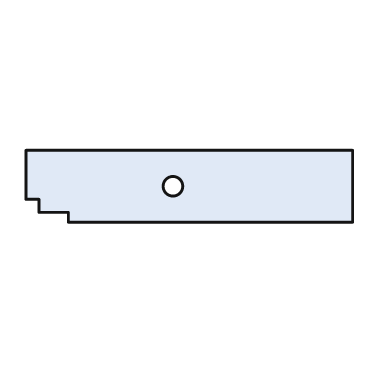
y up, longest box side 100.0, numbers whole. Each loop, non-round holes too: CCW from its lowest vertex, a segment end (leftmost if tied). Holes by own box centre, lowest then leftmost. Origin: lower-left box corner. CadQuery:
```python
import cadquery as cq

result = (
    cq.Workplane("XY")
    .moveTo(13.0, 0.0)
    .lineTo(100.0, 0.0)
    .lineTo(100.0, 22.0)
    .lineTo(0.0, 22.0)
    .lineTo(0.0, 7.0)
    .lineTo(4.0, 7.0)
    .lineTo(4.0, 3.0)
    .lineTo(13.0, 3.0)
    .close()
    .moveTo(45.0, 11.0)
    .circle(3.0)
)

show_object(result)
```